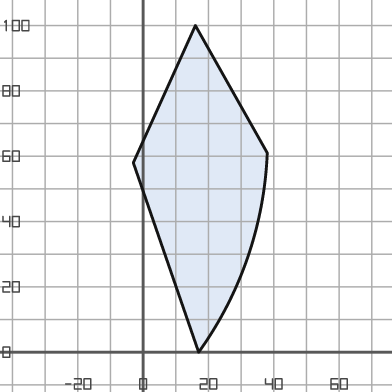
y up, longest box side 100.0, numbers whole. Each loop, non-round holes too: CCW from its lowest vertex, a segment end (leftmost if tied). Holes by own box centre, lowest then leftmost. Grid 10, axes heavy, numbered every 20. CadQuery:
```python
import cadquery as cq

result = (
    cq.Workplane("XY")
    .moveTo(17.0, 0.0)
    .threePointArc((32.0, 29.0), (38.0, 61.0))
    .lineTo(16.0, 100.0)
    .lineTo(-3.0, 58.0)
    .close()
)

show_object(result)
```